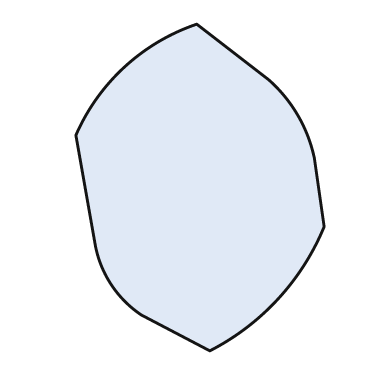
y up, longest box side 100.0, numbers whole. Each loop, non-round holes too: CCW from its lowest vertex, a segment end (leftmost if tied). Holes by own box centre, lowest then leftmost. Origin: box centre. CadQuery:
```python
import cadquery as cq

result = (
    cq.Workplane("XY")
    .moveTo(3.0, -50.0)
    .threePointArc((24.0, -34.0), (38.0, -12.0))
    .lineTo(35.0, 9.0)
    .threePointArc((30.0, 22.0), (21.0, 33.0))
    .lineTo(-1.0, 50.0)
    .threePointArc((-23.0, 37.0), (-38.0, 16.0))
    .lineTo(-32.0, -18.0)
    .threePointArc((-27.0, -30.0), (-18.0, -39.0))
    .close()
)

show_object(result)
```